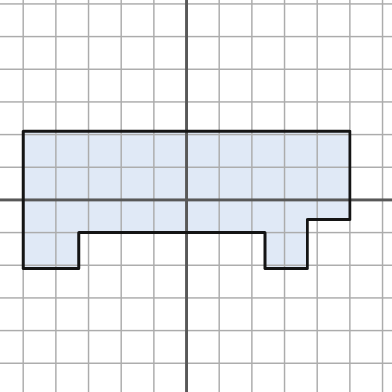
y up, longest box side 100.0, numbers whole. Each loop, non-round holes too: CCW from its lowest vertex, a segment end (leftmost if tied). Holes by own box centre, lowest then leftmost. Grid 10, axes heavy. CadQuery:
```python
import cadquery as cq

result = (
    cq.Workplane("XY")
    .moveTo(-50.0, -21.0)
    .lineTo(-33.0, -21.0)
    .lineTo(-33.0, -10.0)
    .lineTo(24.0, -10.0)
    .lineTo(24.0, -21.0)
    .lineTo(37.0, -21.0)
    .lineTo(37.0, -6.0)
    .lineTo(50.0, -6.0)
    .lineTo(50.0, 21.0)
    .lineTo(-50.0, 21.0)
    .close()
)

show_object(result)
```